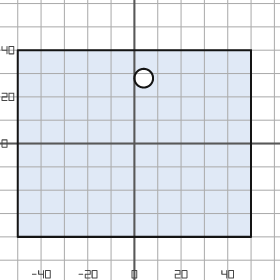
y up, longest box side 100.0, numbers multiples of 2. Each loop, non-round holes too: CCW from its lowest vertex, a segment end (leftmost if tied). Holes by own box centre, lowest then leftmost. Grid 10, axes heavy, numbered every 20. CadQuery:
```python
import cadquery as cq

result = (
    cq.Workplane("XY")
    .moveTo(-50.0, -40.0)
    .lineTo(50.0, -40.0)
    .lineTo(50.0, 40.0)
    .lineTo(-50.0, 40.0)
    .close()
    .moveTo(4.0, 28.0)
    .circle(4.0)
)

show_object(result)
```